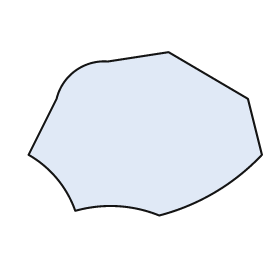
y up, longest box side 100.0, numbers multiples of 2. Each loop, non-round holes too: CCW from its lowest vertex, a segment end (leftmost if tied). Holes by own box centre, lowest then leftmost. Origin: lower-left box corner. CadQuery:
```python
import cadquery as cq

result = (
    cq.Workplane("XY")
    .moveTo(56.0, 0.0)
    .threePointArc((80.0, 10.0), (100.0, 26.0))
    .lineTo(94.0, 50.0)
    .lineTo(60.0, 70.0)
    .lineTo(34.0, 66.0)
    .threePointArc((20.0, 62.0), (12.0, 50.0))
    .lineTo(0.0, 26.0)
    .threePointArc((12.0, 16.0), (20.0, 2.0))
    .threePointArc((38.0, 4.0), (56.0, 0.0))
    .close()
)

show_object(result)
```